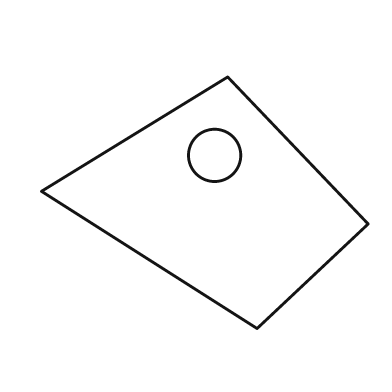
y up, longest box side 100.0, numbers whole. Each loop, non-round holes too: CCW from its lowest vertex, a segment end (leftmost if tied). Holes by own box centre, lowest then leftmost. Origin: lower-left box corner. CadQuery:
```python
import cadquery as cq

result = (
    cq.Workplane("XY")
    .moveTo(66.0, 0.0)
    .lineTo(100.0, 32.0)
    .lineTo(57.0, 77.0)
    .lineTo(0.0, 42.0)
    .close()
    .moveTo(53.0, 53.0)
    .circle(8.0)
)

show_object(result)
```